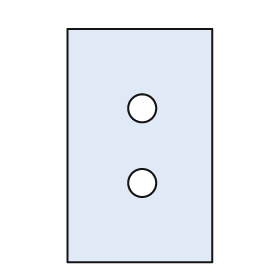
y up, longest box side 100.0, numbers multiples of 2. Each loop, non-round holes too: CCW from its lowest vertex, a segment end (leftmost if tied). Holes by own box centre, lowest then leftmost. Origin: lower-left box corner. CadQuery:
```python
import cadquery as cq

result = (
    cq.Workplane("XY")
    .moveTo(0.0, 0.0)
    .lineTo(62.0, 0.0)
    .lineTo(62.0, 100.0)
    .lineTo(0.0, 100.0)
    .close()
    .moveTo(32.0, 34.0)
    .circle(6.0)
    .moveTo(32.0, 66.0)
    .circle(6.0)
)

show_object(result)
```